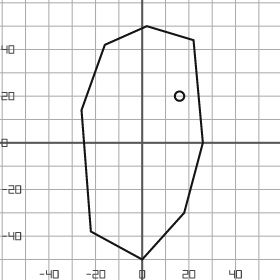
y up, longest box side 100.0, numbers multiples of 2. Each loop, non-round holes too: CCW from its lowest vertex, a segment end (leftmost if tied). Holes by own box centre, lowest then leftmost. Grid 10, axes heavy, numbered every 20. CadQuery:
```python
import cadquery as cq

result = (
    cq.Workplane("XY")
    .moveTo(0.0, -50.0)
    .lineTo(18.0, -30.0)
    .lineTo(26.0, 0.0)
    .lineTo(22.0, 44.0)
    .lineTo(2.0, 50.0)
    .lineTo(-16.0, 42.0)
    .lineTo(-26.0, 14.0)
    .lineTo(-22.0, -38.0)
    .close()
    .moveTo(16.0, 20.0)
    .circle(2.0)
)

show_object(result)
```